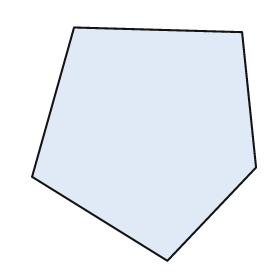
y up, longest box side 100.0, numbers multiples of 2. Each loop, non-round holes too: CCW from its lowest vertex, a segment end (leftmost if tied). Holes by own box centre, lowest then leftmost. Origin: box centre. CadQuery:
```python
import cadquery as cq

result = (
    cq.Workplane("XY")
    .moveTo(10.0, -50.0)
    .lineTo(48.0, -10.0)
    .lineTo(42.0, 48.0)
    .lineTo(-30.0, 50.0)
    .lineTo(-48.0, -14.0)
    .close()
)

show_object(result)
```